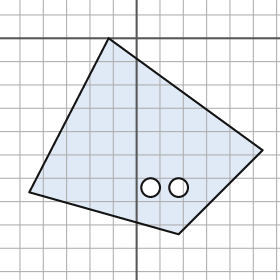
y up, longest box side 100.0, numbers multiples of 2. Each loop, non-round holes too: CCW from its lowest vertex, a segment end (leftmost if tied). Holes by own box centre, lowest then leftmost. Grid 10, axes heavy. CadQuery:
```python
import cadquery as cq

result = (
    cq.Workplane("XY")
    .moveTo(18.0, -84.0)
    .lineTo(54.0, -48.0)
    .lineTo(-12.0, 0.0)
    .lineTo(-46.0, -66.0)
    .close()
    .moveTo(6.0, -64.0)
    .circle(4.0)
    .moveTo(18.0, -64.0)
    .circle(4.0)
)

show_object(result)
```